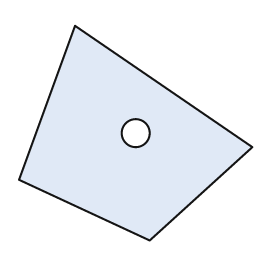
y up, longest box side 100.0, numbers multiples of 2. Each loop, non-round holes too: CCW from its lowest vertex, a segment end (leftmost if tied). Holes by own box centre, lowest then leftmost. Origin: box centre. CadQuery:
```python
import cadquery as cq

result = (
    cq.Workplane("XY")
    .moveTo(6.0, -46.0)
    .lineTo(50.0, -6.0)
    .lineTo(-26.0, 46.0)
    .lineTo(-50.0, -20.0)
    .close()
    .moveTo(0.0, 0.0)
    .circle(6.0)
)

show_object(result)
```